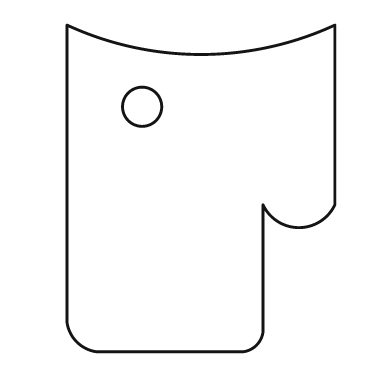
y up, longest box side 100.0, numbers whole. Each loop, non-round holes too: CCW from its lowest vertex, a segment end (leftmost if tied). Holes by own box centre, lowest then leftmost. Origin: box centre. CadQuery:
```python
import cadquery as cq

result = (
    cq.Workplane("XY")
    .moveTo(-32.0, -50.0)
    .lineTo(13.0, -50.0)
    .threePointArc((17.0, -48.0), (19.0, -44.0))
    .lineTo(19.0, -5.0)
    .threePointArc((30.0, -12.0), (41.0, -5.0))
    .lineTo(41.0, 50.0)
    .threePointArc((0.0, 41.0), (-41.0, 50.0))
    .lineTo(-41.0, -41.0)
    .threePointArc((-38.0, -47.0), (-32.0, -50.0))
    .close()
    .moveTo(-18.0, 25.0)
    .circle(6.0)
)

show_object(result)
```